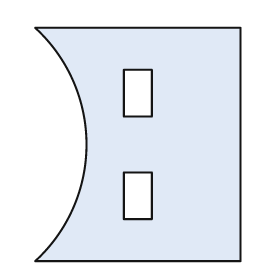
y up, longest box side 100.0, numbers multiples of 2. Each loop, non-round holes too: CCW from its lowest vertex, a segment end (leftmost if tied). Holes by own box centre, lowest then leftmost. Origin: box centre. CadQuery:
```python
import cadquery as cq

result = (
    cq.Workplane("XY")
    .moveTo(-44.0, -50.0)
    .lineTo(44.0, -50.0)
    .lineTo(44.0, 50.0)
    .lineTo(-44.0, 50.0)
    .threePointArc((-22.0, 0.0), (-44.0, -50.0))
    .close()
    .moveTo(-6.0, -32.0)
    .lineTo(6.0, -32.0)
    .lineTo(6.0, -12.0)
    .lineTo(-6.0, -12.0)
    .close()
    .moveTo(-6.0, 12.0)
    .lineTo(6.0, 12.0)
    .lineTo(6.0, 32.0)
    .lineTo(-6.0, 32.0)
    .close()
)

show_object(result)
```